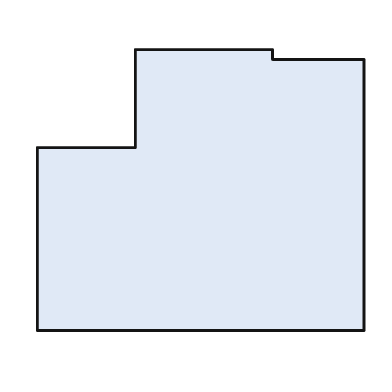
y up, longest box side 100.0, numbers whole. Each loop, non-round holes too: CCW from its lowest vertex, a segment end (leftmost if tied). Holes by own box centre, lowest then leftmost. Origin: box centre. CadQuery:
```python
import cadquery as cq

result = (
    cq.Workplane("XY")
    .moveTo(-50.0, -43.0)
    .lineTo(50.0, -43.0)
    .lineTo(50.0, 40.0)
    .lineTo(22.0, 40.0)
    .lineTo(22.0, 43.0)
    .lineTo(-20.0, 43.0)
    .lineTo(-20.0, 13.0)
    .lineTo(-50.0, 13.0)
    .close()
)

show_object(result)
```